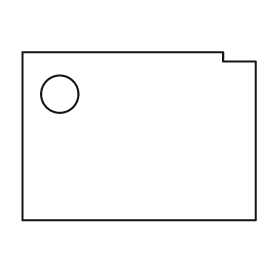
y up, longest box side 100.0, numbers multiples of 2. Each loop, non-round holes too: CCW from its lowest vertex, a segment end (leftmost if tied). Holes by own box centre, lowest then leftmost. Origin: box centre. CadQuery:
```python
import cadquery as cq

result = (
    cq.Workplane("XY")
    .moveTo(-50.0, -36.0)
    .lineTo(50.0, -36.0)
    .lineTo(50.0, 32.0)
    .lineTo(36.0, 32.0)
    .lineTo(36.0, 36.0)
    .lineTo(-50.0, 36.0)
    .close()
    .moveTo(-34.0, 18.0)
    .circle(8.0)
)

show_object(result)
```